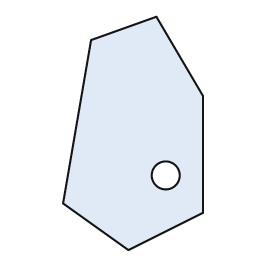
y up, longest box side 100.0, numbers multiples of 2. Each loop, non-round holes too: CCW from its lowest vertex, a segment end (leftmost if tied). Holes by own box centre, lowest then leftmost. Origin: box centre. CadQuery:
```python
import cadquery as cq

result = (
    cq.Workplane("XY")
    .moveTo(-2.0, -50.0)
    .lineTo(30.0, -34.0)
    .lineTo(30.0, 16.0)
    .lineTo(10.0, 50.0)
    .lineTo(-18.0, 40.0)
    .lineTo(-30.0, -30.0)
    .close()
    .moveTo(14.0, -18.0)
    .circle(6.0)
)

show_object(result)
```